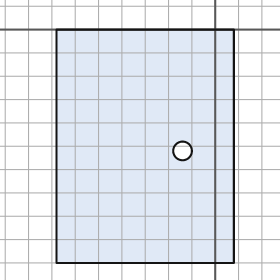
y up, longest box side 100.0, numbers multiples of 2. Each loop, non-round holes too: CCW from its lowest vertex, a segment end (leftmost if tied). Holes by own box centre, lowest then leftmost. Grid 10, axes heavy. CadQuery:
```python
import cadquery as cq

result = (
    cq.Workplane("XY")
    .moveTo(-68.0, -100.0)
    .lineTo(8.0, -100.0)
    .lineTo(8.0, 0.0)
    .lineTo(-68.0, 0.0)
    .close()
    .moveTo(-14.0, -52.0)
    .circle(4.0)
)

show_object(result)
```